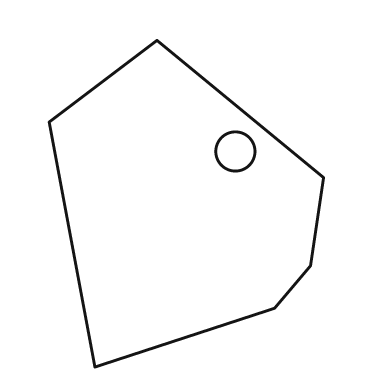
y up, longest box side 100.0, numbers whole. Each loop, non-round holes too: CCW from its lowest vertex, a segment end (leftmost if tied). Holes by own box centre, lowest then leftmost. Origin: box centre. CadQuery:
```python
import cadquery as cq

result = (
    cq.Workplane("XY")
    .moveTo(-28.0, -50.0)
    .lineTo(27.0, -32.0)
    .lineTo(38.0, -19.0)
    .lineTo(42.0, 8.0)
    .lineTo(-9.0, 50.0)
    .lineTo(-42.0, 25.0)
    .close()
    .moveTo(15.0, 16.0)
    .circle(6.0)
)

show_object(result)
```